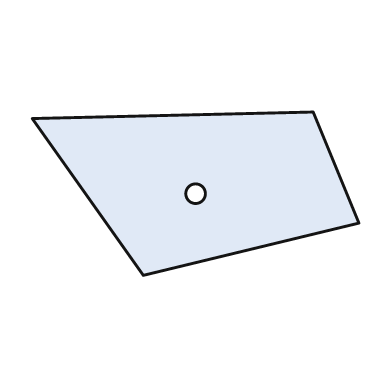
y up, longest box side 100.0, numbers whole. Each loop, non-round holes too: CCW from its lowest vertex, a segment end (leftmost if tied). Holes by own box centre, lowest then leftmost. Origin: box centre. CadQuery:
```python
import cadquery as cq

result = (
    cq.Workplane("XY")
    .moveTo(-16.0, -25.0)
    .lineTo(50.0, -9.0)
    .lineTo(36.0, 25.0)
    .lineTo(-50.0, 23.0)
    .close()
    .moveTo(0.0, 0.0)
    .circle(3.0)
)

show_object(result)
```